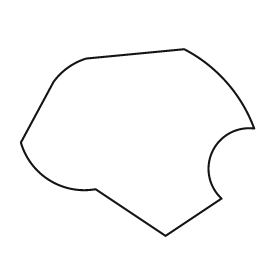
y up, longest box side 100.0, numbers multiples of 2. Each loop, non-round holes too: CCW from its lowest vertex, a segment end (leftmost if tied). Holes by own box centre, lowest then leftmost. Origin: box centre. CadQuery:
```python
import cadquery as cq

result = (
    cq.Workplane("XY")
    .moveTo(12.0, -40.0)
    .lineTo(36.0, -24.0)
    .threePointArc((32.0, -4.0), (50.0, 6.0))
    .threePointArc((38.0, 26.0), (20.0, 40.0))
    .lineTo(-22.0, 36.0)
    .threePointArc((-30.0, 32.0), (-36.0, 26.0))
    .lineTo(-50.0, 0.0)
    .threePointArc((-38.0, -16.0), (-18.0, -20.0))
    .close()
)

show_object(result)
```